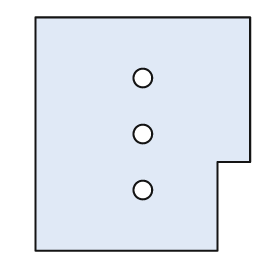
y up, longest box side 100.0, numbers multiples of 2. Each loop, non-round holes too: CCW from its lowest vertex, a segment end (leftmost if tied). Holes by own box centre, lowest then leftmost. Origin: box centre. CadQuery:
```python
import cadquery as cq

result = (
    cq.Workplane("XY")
    .moveTo(-46.0, -50.0)
    .lineTo(32.0, -50.0)
    .lineTo(32.0, -12.0)
    .lineTo(46.0, -12.0)
    .lineTo(46.0, 50.0)
    .lineTo(-46.0, 50.0)
    .close()
    .moveTo(0.0, -24.0)
    .circle(4.0)
    .moveTo(0.0, 0.0)
    .circle(4.0)
    .moveTo(0.0, 24.0)
    .circle(4.0)
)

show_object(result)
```